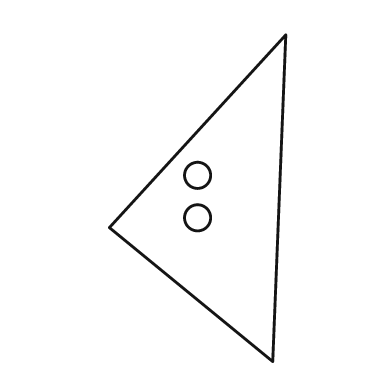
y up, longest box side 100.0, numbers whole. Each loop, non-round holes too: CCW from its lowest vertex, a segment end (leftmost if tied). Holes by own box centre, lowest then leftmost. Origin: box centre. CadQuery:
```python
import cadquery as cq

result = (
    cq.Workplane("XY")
    .moveTo(23.0, -50.0)
    .lineTo(27.0, 50.0)
    .lineTo(-27.0, -9.0)
    .close()
    .moveTo(0.0, -6.0)
    .circle(4.0)
    .moveTo(0.0, 7.0)
    .circle(4.0)
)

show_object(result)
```